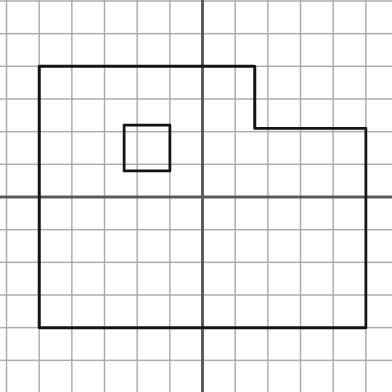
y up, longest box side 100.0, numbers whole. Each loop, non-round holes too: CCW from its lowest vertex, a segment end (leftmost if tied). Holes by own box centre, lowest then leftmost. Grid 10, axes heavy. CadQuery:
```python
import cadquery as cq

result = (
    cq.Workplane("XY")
    .moveTo(-50.0, -40.0)
    .lineTo(50.0, -40.0)
    .lineTo(50.0, 21.0)
    .lineTo(16.0, 21.0)
    .lineTo(16.0, 40.0)
    .lineTo(-50.0, 40.0)
    .close()
    .moveTo(-24.0, 8.0)
    .lineTo(-10.0, 8.0)
    .lineTo(-10.0, 22.0)
    .lineTo(-24.0, 22.0)
    .close()
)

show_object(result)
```